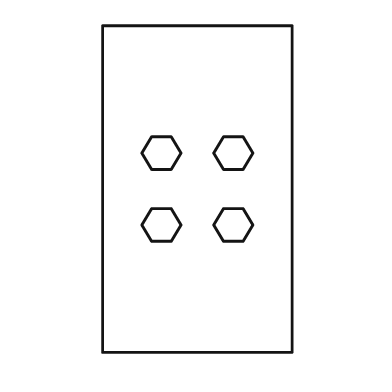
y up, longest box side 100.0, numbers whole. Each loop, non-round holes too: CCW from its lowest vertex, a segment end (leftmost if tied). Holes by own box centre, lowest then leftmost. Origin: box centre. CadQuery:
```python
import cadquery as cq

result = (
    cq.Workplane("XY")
    .moveTo(-29.0, -50.0)
    .lineTo(29.0, -50.0)
    .lineTo(29.0, 50.0)
    .lineTo(-29.0, 50.0)
    .close()
    .moveTo(-14.0, -16.0)
    .lineTo(-8.0, -16.0)
    .lineTo(-5.0, -11.0)
    .lineTo(-8.0, -6.0)
    .lineTo(-14.0, -6.0)
    .lineTo(-17.0, -11.0)
    .close()
    .moveTo(8.0, -16.0)
    .lineTo(14.0, -16.0)
    .lineTo(17.0, -11.0)
    .lineTo(14.0, -6.0)
    .lineTo(8.0, -6.0)
    .lineTo(5.0, -11.0)
    .close()
    .moveTo(-14.0, 6.0)
    .lineTo(-8.0, 6.0)
    .lineTo(-5.0, 11.0)
    .lineTo(-8.0, 16.0)
    .lineTo(-14.0, 16.0)
    .lineTo(-17.0, 11.0)
    .close()
    .moveTo(8.0, 6.0)
    .lineTo(14.0, 6.0)
    .lineTo(17.0, 11.0)
    .lineTo(14.0, 16.0)
    .lineTo(8.0, 16.0)
    .lineTo(5.0, 11.0)
    .close()
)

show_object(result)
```